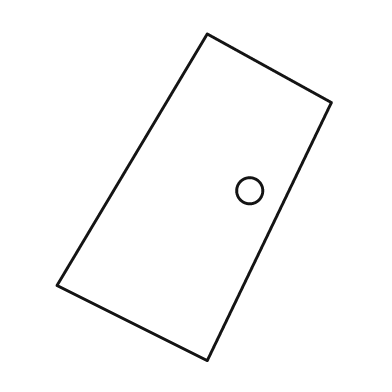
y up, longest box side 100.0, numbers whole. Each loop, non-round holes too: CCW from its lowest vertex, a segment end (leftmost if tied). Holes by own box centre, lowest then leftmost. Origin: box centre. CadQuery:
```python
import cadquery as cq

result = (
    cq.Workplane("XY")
    .moveTo(4.0, -50.0)
    .lineTo(42.0, 29.0)
    .lineTo(4.0, 50.0)
    .lineTo(-42.0, -27.0)
    .close()
    .moveTo(17.0, 2.0)
    .circle(4.0)
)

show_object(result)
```